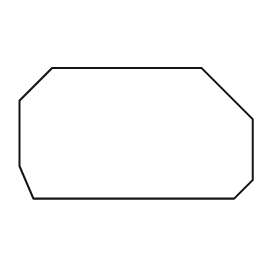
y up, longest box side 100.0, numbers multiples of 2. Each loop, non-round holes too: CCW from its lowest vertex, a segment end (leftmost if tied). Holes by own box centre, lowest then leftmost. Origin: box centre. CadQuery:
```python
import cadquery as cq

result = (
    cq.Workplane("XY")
    .moveTo(-44.0, -28.0)
    .lineTo(42.0, -28.0)
    .lineTo(50.0, -20.0)
    .lineTo(50.0, 6.0)
    .lineTo(28.0, 28.0)
    .lineTo(-36.0, 28.0)
    .lineTo(-50.0, 14.0)
    .lineTo(-50.0, -14.0)
    .close()
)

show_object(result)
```